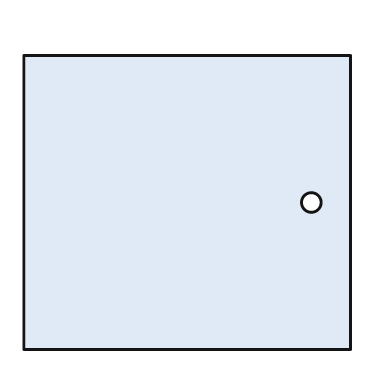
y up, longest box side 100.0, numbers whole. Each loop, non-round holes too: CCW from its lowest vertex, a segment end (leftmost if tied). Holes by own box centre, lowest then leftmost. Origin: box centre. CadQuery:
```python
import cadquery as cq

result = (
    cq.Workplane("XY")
    .moveTo(-50.0, -45.0)
    .lineTo(50.0, -45.0)
    .lineTo(50.0, 45.0)
    .lineTo(-50.0, 45.0)
    .close()
    .moveTo(38.0, 0.0)
    .circle(3.0)
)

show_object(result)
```